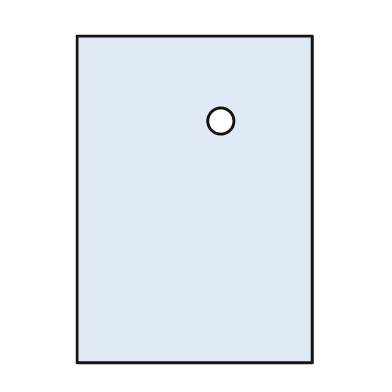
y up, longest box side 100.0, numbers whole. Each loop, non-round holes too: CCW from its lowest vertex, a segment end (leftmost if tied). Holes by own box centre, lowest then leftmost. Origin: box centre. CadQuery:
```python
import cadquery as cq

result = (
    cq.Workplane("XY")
    .moveTo(-36.0, -50.0)
    .lineTo(36.0, -50.0)
    .lineTo(36.0, 50.0)
    .lineTo(-36.0, 50.0)
    .close()
    .moveTo(8.0, 24.0)
    .circle(4.0)
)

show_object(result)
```